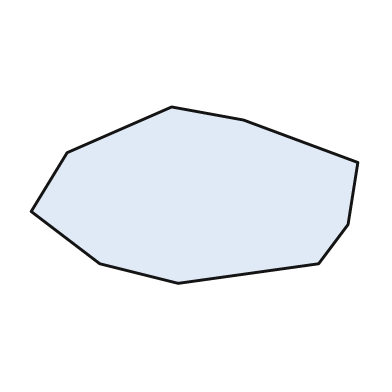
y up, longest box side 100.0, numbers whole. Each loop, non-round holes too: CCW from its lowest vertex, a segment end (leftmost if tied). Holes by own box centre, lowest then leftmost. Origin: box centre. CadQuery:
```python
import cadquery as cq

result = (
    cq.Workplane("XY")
    .moveTo(-5.0, -27.0)
    .lineTo(38.0, -21.0)
    .lineTo(47.0, -9.0)
    .lineTo(50.0, 10.0)
    .lineTo(15.0, 23.0)
    .lineTo(-7.0, 27.0)
    .lineTo(-39.0, 13.0)
    .lineTo(-50.0, -5.0)
    .lineTo(-29.0, -21.0)
    .close()
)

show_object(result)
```